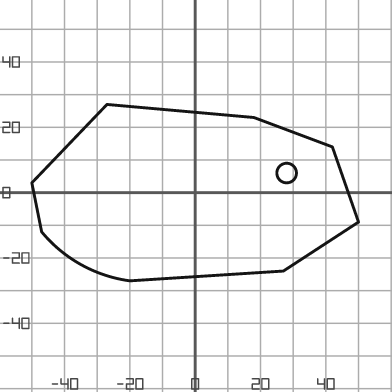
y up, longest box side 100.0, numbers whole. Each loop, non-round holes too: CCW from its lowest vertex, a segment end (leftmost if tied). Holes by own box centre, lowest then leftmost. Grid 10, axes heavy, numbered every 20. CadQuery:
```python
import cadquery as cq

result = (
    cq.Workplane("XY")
    .moveTo(-20.0, -27.0)
    .lineTo(27.0, -24.0)
    .lineTo(50.0, -9.0)
    .lineTo(42.0, 14.0)
    .lineTo(18.0, 23.0)
    .lineTo(-27.0, 27.0)
    .lineTo(-50.0, 3.0)
    .lineTo(-47.0, -12.0)
    .threePointArc((-35.0, -22.0), (-20.0, -27.0))
    .close()
    .moveTo(28.0, 6.0)
    .circle(3.0)
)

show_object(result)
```